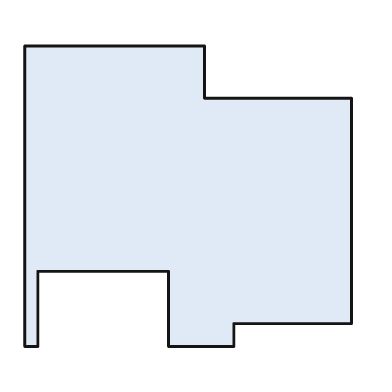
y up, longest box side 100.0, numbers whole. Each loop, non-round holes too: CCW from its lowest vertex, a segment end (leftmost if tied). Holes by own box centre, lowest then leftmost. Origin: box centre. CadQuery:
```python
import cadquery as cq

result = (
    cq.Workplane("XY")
    .moveTo(-50.0, -46.0)
    .lineTo(-46.0, -46.0)
    .lineTo(-46.0, -23.0)
    .lineTo(-6.0, -23.0)
    .lineTo(-6.0, -46.0)
    .lineTo(14.0, -46.0)
    .lineTo(14.0, -39.0)
    .lineTo(50.0, -39.0)
    .lineTo(50.0, 30.0)
    .lineTo(5.0, 30.0)
    .lineTo(5.0, 46.0)
    .lineTo(-50.0, 46.0)
    .close()
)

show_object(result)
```